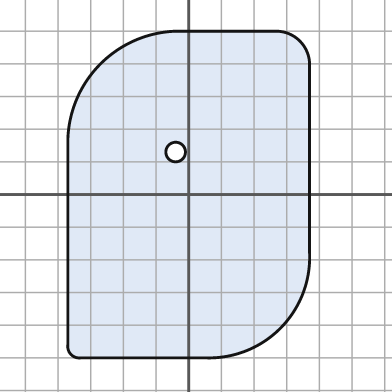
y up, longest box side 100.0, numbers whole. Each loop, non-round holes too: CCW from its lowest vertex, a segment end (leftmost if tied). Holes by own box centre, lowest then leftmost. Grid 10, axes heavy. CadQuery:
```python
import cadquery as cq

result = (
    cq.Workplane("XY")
    .moveTo(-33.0, -50.0)
    .lineTo(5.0, -50.0)
    .threePointArc((28.0, -41.0), (37.0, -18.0))
    .lineTo(37.0, 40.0)
    .threePointArc((34.0, 47.0), (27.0, 50.0))
    .lineTo(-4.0, 50.0)
    .threePointArc((-27.0, 40.0), (-37.0, 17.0))
    .lineTo(-37.0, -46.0)
    .threePointArc((-36.0, -49.0), (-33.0, -50.0))
    .close()
    .moveTo(-4.0, 13.0)
    .circle(3.0)
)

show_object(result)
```